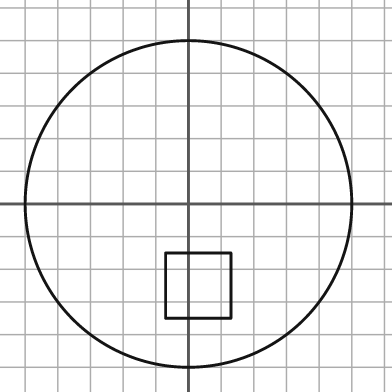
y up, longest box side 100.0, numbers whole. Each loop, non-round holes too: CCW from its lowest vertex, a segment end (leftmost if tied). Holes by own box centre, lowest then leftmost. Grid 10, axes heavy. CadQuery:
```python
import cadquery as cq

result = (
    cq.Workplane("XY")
    .moveTo(0.0, 0.0)
    .circle(50.0)
    .moveTo(-7.0, -35.0)
    .lineTo(13.0, -35.0)
    .lineTo(13.0, -15.0)
    .lineTo(-7.0, -15.0)
    .close()
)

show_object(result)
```